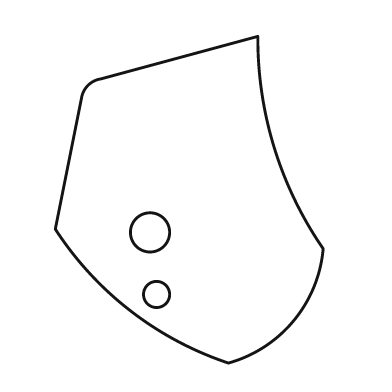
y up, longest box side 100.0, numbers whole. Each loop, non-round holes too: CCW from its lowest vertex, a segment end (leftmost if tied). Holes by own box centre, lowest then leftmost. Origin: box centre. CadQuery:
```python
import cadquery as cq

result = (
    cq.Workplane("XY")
    .moveTo(12.0, -50.0)
    .threePointArc((32.0, -37.0), (41.0, -15.0))
    .threePointArc((26.0, 16.0), (21.0, 50.0))
    .lineTo(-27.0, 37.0)
    .threePointArc((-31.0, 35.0), (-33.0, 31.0))
    .lineTo(-41.0, -9.0)
    .threePointArc((-18.0, -34.0), (12.0, -50.0))
    .close()
    .moveTo(-10.0, -29.0)
    .circle(4.0)
    .moveTo(-12.0, -10.0)
    .circle(6.0)
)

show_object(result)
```